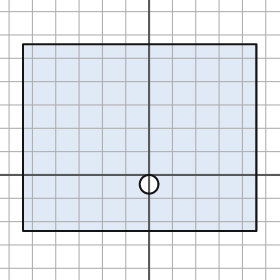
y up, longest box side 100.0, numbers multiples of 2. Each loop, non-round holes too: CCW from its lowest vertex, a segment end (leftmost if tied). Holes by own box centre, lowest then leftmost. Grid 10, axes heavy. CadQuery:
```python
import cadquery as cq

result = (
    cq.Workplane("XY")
    .moveTo(-54.0, -24.0)
    .lineTo(46.0, -24.0)
    .lineTo(46.0, 56.0)
    .lineTo(-54.0, 56.0)
    .close()
    .moveTo(0.0, -4.0)
    .circle(4.0)
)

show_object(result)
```